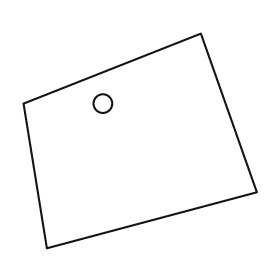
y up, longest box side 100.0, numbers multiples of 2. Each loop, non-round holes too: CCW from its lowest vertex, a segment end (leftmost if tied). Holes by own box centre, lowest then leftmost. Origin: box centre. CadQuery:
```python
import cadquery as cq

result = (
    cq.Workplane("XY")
    .moveTo(-40.0, -46.0)
    .lineTo(50.0, -22.0)
    .lineTo(26.0, 46.0)
    .lineTo(-50.0, 16.0)
    .close()
    .moveTo(-16.0, 16.0)
    .circle(4.0)
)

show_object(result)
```